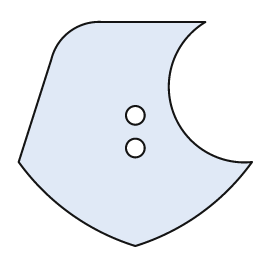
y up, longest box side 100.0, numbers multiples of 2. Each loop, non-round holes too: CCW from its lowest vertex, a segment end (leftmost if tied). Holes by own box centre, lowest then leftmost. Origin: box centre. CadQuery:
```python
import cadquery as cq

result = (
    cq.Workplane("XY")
    .moveTo(0.0, -48.0)
    .threePointArc((28.0, -34.0), (50.0, -12.0))
    .threePointArc((16.0, 10.0), (30.0, 48.0))
    .lineTo(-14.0, 48.0)
    .threePointArc((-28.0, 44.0), (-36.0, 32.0))
    .lineTo(-50.0, -12.0)
    .threePointArc((-28.0, -34.0), (0.0, -48.0))
    .close()
    .moveTo(0.0, -6.0)
    .circle(4.0)
    .moveTo(0.0, 8.0)
    .circle(4.0)
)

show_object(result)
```